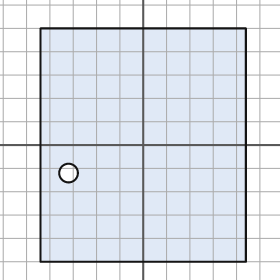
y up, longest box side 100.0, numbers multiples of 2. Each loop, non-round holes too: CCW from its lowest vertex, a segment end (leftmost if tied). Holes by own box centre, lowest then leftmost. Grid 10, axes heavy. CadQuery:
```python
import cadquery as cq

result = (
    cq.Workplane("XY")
    .moveTo(-44.0, -50.0)
    .lineTo(44.0, -50.0)
    .lineTo(44.0, 50.0)
    .lineTo(-44.0, 50.0)
    .close()
    .moveTo(-32.0, -12.0)
    .circle(4.0)
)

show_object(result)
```